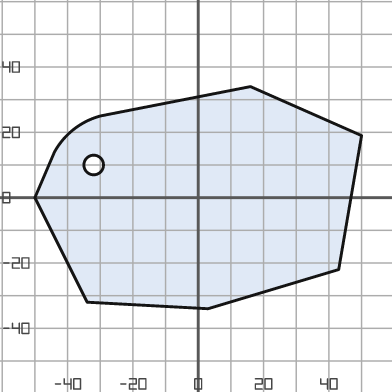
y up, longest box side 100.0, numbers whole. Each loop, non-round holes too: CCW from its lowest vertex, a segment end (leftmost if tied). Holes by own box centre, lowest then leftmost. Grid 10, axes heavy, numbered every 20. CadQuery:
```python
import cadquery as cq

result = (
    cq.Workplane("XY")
    .moveTo(3.0, -34.0)
    .lineTo(43.0, -22.0)
    .lineTo(50.0, 19.0)
    .lineTo(16.0, 34.0)
    .lineTo(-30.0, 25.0)
    .threePointArc((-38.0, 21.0), (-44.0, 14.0))
    .lineTo(-50.0, 0.0)
    .lineTo(-34.0, -32.0)
    .close()
    .moveTo(-32.0, 10.0)
    .circle(3.0)
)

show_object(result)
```